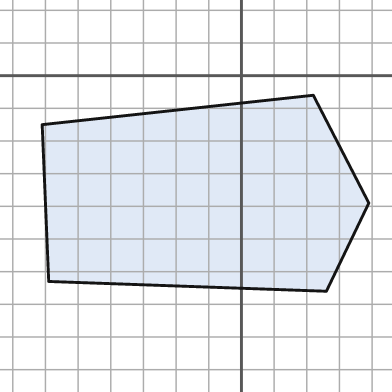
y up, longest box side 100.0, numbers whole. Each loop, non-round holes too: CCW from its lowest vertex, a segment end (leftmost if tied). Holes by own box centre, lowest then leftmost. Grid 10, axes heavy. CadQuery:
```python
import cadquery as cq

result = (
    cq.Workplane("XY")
    .moveTo(26.0, -66.0)
    .lineTo(39.0, -39.0)
    .lineTo(22.0, -6.0)
    .lineTo(-61.0, -15.0)
    .lineTo(-59.0, -63.0)
    .close()
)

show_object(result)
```